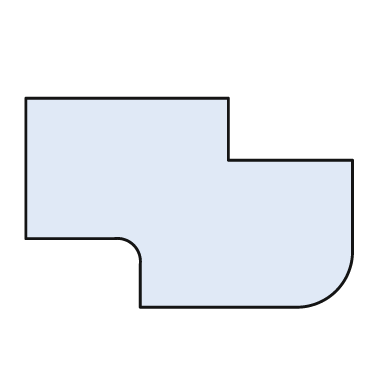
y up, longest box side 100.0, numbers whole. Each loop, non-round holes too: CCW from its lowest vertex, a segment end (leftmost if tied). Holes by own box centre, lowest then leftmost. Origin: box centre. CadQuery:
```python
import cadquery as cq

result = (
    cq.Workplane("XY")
    .moveTo(-15.0, -32.0)
    .lineTo(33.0, -32.0)
    .threePointArc((45.0, -27.0), (50.0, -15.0))
    .lineTo(50.0, 13.0)
    .lineTo(12.0, 13.0)
    .lineTo(12.0, 32.0)
    .lineTo(-50.0, 32.0)
    .lineTo(-50.0, -11.0)
    .lineTo(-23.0, -11.0)
    .threePointArc((-17.0, -13.0), (-15.0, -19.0))
    .close()
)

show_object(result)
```